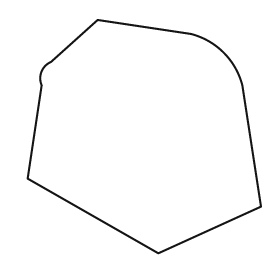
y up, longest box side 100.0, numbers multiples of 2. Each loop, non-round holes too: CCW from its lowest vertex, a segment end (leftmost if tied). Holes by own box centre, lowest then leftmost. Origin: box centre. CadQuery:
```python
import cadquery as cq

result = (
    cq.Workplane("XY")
    .moveTo(6.0, -50.0)
    .lineTo(50.0, -30.0)
    .lineTo(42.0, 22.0)
    .threePointArc((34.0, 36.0), (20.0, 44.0))
    .lineTo(-20.0, 50.0)
    .lineTo(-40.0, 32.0)
    .threePointArc((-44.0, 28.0), (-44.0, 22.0))
    .lineTo(-50.0, -18.0)
    .close()
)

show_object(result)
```